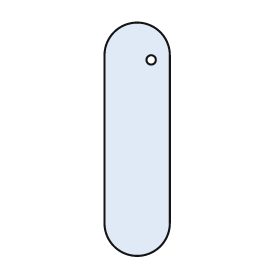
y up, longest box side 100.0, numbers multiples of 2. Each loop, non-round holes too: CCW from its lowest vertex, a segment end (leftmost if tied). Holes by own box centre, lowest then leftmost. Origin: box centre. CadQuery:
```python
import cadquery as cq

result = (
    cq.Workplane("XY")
    .moveTo(-14.0, -36.0)
    .threePointArc((0.0, -50.0), (14.0, -36.0))
    .lineTo(14.0, 36.0)
    .threePointArc((0.0, 50.0), (-14.0, 36.0))
    .close()
    .moveTo(6.0, 34.0)
    .circle(2.0)
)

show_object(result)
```